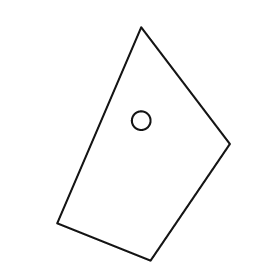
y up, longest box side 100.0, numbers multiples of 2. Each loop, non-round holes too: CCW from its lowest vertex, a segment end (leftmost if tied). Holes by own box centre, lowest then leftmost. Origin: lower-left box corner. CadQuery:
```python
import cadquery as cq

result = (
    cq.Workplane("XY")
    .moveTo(40.0, 0.0)
    .lineTo(74.0, 50.0)
    .lineTo(36.0, 100.0)
    .lineTo(0.0, 16.0)
    .close()
    .moveTo(36.0, 60.0)
    .circle(4.0)
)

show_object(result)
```